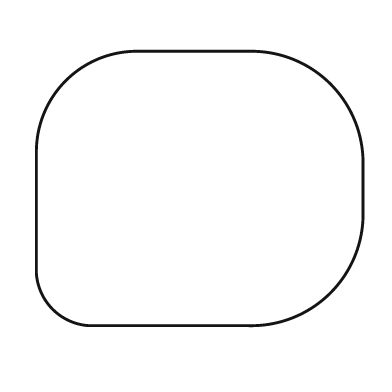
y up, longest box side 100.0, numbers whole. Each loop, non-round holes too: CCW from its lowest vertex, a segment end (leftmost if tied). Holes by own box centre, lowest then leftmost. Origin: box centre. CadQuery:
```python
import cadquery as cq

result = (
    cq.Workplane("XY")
    .moveTo(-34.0, -42.0)
    .lineTo(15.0, -42.0)
    .threePointArc((40.0, -32.0), (50.0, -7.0))
    .lineTo(50.0, 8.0)
    .threePointArc((40.0, 32.0), (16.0, 42.0))
    .lineTo(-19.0, 42.0)
    .threePointArc((-41.0, 33.0), (-50.0, 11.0))
    .lineTo(-50.0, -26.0)
    .threePointArc((-45.0, -37.0), (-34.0, -42.0))
    .close()
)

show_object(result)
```